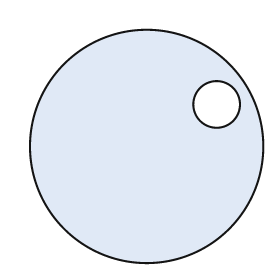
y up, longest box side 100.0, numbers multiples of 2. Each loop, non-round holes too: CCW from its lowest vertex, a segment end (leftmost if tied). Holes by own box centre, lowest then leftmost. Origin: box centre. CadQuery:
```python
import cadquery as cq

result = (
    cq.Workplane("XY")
    .moveTo(0.0, 0.0)
    .circle(50.0)
    .moveTo(30.0, 18.0)
    .circle(10.0)
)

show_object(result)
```